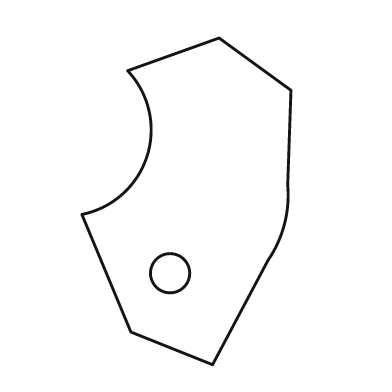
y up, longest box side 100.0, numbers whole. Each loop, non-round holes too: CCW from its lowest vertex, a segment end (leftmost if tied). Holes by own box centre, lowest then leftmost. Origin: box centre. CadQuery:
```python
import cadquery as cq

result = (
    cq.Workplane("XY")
    .moveTo(8.0, -50.0)
    .lineTo(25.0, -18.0)
    .threePointArc((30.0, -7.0), (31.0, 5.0))
    .lineTo(32.0, 34.0)
    .lineTo(10.0, 50.0)
    .lineTo(-18.0, 40.0)
    .threePointArc((-12.0, 14.0), (-32.0, -4.0))
    .lineTo(-17.0, -40.0)
    .close()
    .moveTo(-5.0, -22.0)
    .circle(6.0)
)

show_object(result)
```